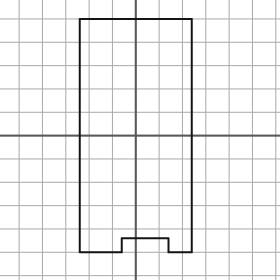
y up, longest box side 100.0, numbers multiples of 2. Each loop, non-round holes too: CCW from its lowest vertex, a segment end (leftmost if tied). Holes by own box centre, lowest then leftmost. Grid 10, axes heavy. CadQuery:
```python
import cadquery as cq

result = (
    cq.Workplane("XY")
    .moveTo(-24.0, -50.0)
    .lineTo(-6.0, -50.0)
    .lineTo(-6.0, -44.0)
    .lineTo(14.0, -44.0)
    .lineTo(14.0, -50.0)
    .lineTo(24.0, -50.0)
    .lineTo(24.0, 50.0)
    .lineTo(-24.0, 50.0)
    .close()
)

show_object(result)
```